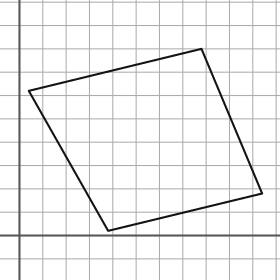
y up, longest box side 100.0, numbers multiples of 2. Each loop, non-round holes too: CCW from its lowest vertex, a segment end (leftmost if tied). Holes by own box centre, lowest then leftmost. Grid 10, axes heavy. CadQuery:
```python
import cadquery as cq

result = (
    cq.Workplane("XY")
    .moveTo(38.0, 2.0)
    .lineTo(104.0, 18.0)
    .lineTo(78.0, 80.0)
    .lineTo(4.0, 62.0)
    .close()
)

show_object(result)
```